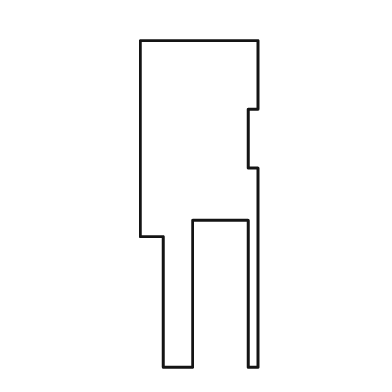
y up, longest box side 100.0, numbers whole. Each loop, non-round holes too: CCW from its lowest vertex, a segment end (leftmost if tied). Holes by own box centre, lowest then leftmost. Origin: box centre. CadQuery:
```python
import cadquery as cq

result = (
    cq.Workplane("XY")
    .moveTo(-11.0, -50.0)
    .lineTo(-2.0, -50.0)
    .lineTo(-2.0, -5.0)
    .lineTo(15.0, -5.0)
    .lineTo(15.0, -50.0)
    .lineTo(18.0, -50.0)
    .lineTo(18.0, 11.0)
    .lineTo(15.0, 11.0)
    .lineTo(15.0, 29.0)
    .lineTo(18.0, 29.0)
    .lineTo(18.0, 50.0)
    .lineTo(-18.0, 50.0)
    .lineTo(-18.0, -10.0)
    .lineTo(-11.0, -10.0)
    .close()
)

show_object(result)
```